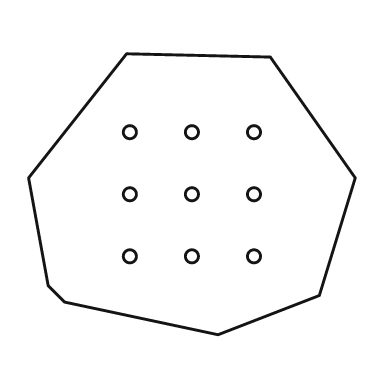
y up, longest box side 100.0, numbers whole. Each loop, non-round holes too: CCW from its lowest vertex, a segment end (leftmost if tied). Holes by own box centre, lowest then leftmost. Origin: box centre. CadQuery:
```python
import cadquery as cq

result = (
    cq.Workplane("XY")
    .moveTo(8.0, -43.0)
    .lineTo(39.0, -31.0)
    .lineTo(50.0, 5.0)
    .lineTo(24.0, 42.0)
    .lineTo(-20.0, 43.0)
    .lineTo(-50.0, 5.0)
    .lineTo(-44.0, -28.0)
    .lineTo(-39.0, -33.0)
    .close()
    .moveTo(-19.0, -19.0)
    .circle(2.0)
    .moveTo(0.0, -19.0)
    .circle(2.0)
    .moveTo(19.0, -19.0)
    .circle(2.0)
    .moveTo(-19.0, 0.0)
    .circle(2.0)
    .moveTo(0.0, 0.0)
    .circle(2.0)
    .moveTo(19.0, 0.0)
    .circle(2.0)
    .moveTo(-19.0, 19.0)
    .circle(2.0)
    .moveTo(0.0, 19.0)
    .circle(2.0)
    .moveTo(19.0, 19.0)
    .circle(2.0)
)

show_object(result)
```